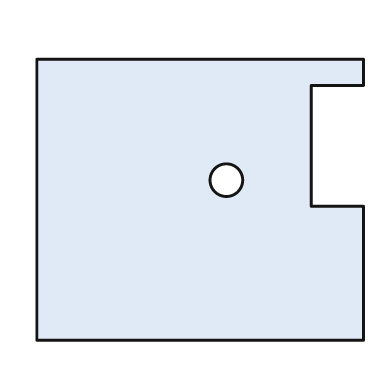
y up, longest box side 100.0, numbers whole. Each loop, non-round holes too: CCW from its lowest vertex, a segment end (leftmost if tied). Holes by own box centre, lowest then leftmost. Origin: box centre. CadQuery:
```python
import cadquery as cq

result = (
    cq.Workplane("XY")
    .moveTo(-50.0, -43.0)
    .lineTo(50.0, -43.0)
    .lineTo(50.0, -2.0)
    .lineTo(34.0, -2.0)
    .lineTo(34.0, 35.0)
    .lineTo(50.0, 35.0)
    .lineTo(50.0, 43.0)
    .lineTo(-50.0, 43.0)
    .close()
    .moveTo(8.0, 6.0)
    .circle(5.0)
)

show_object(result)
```